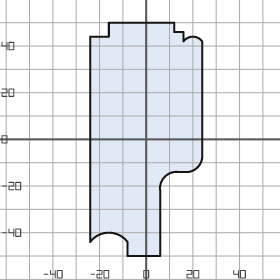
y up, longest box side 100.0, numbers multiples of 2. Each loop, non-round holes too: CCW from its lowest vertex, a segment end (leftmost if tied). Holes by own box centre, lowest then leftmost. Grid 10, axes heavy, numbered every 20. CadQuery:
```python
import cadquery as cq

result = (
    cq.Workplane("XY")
    .moveTo(-8.0, -50.0)
    .lineTo(6.0, -50.0)
    .lineTo(6.0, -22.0)
    .threePointArc((8.0, -16.0), (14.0, -14.0))
    .lineTo(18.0, -14.0)
    .threePointArc((22.0, -12.0), (24.0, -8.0))
    .lineTo(24.0, 42.0)
    .threePointArc((20.0, 44.0), (16.0, 42.0))
    .lineTo(16.0, 46.0)
    .lineTo(12.0, 46.0)
    .lineTo(12.0, 50.0)
    .lineTo(-16.0, 50.0)
    .lineTo(-16.0, 44.0)
    .lineTo(-24.0, 44.0)
    .lineTo(-24.0, -44.0)
    .threePointArc((-16.0, -40.0), (-8.0, -44.0))
    .close()
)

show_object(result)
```